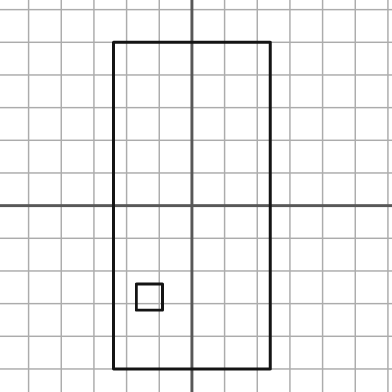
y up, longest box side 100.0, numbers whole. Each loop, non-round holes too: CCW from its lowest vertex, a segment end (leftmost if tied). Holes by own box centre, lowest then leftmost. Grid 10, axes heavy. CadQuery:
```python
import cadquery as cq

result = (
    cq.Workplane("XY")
    .moveTo(-24.0, -50.0)
    .lineTo(24.0, -50.0)
    .lineTo(24.0, 50.0)
    .lineTo(-24.0, 50.0)
    .close()
    .moveTo(-17.0, -32.0)
    .lineTo(-9.0, -32.0)
    .lineTo(-9.0, -24.0)
    .lineTo(-17.0, -24.0)
    .close()
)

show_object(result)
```